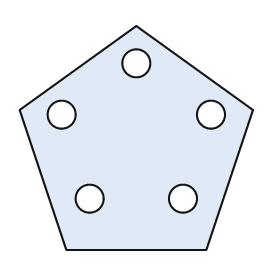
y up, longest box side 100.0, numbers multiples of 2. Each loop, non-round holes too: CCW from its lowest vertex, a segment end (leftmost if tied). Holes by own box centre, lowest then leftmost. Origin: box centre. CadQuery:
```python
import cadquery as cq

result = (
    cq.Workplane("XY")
    .moveTo(-30.0, -48.0)
    .lineTo(30.0, -48.0)
    .lineTo(50.0, 12.0)
    .lineTo(0.0, 48.0)
    .lineTo(-50.0, 12.0)
    .close()
    .moveTo(-20.0, -26.0)
    .circle(6.0)
    .moveTo(20.0, -26.0)
    .circle(6.0)
    .moveTo(-32.0, 10.0)
    .circle(6.0)
    .moveTo(32.0, 10.0)
    .circle(6.0)
    .moveTo(0.0, 32.0)
    .circle(6.0)
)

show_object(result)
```